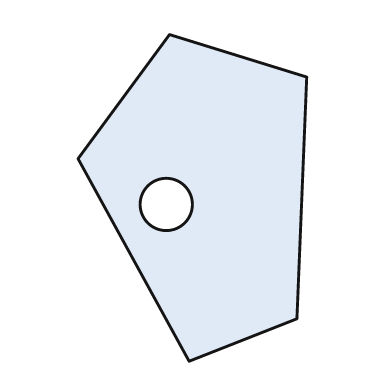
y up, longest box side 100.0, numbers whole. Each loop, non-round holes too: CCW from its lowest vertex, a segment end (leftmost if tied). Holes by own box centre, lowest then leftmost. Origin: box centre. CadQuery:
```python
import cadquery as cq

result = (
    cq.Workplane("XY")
    .moveTo(-1.0, -50.0)
    .lineTo(32.0, -37.0)
    .lineTo(35.0, 37.0)
    .lineTo(-7.0, 50.0)
    .lineTo(-35.0, 12.0)
    .close()
    .moveTo(-8.0, -2.0)
    .circle(8.0)
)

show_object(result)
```